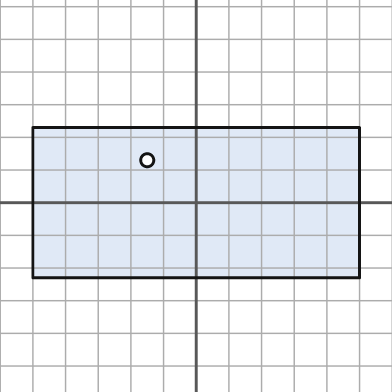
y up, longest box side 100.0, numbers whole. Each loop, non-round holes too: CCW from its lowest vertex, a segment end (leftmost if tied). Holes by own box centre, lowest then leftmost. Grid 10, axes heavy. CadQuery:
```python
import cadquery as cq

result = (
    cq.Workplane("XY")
    .moveTo(-50.0, -23.0)
    .lineTo(50.0, -23.0)
    .lineTo(50.0, 23.0)
    .lineTo(-50.0, 23.0)
    .close()
    .moveTo(-15.0, 13.0)
    .circle(2.0)
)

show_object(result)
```